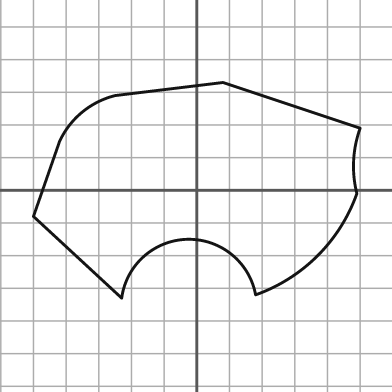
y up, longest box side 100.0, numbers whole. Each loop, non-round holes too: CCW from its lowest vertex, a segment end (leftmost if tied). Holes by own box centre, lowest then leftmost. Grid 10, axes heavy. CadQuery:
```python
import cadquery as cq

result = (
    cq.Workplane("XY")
    .moveTo(-23.0, -33.0)
    .threePointArc((-3.0, -15.0), (18.0, -32.0))
    .threePointArc((37.0, -20.0), (49.0, -1.0))
    .threePointArc((48.0, 9.0), (50.0, 19.0))
    .lineTo(8.0, 33.0)
    .lineTo(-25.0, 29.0)
    .threePointArc((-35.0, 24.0), (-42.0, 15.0))
    .lineTo(-50.0, -8.0)
    .close()
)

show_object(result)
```